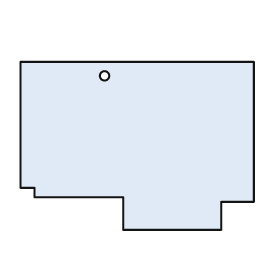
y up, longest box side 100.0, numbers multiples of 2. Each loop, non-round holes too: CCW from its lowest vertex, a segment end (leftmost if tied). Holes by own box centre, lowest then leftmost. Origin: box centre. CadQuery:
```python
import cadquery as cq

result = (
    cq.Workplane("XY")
    .moveTo(-6.0, -36.0)
    .lineTo(36.0, -36.0)
    .lineTo(36.0, -24.0)
    .lineTo(50.0, -24.0)
    .lineTo(50.0, 36.0)
    .lineTo(-50.0, 36.0)
    .lineTo(-50.0, -18.0)
    .lineTo(-44.0, -18.0)
    .lineTo(-44.0, -22.0)
    .lineTo(-6.0, -22.0)
    .close()
    .moveTo(-14.0, 30.0)
    .circle(2.0)
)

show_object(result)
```